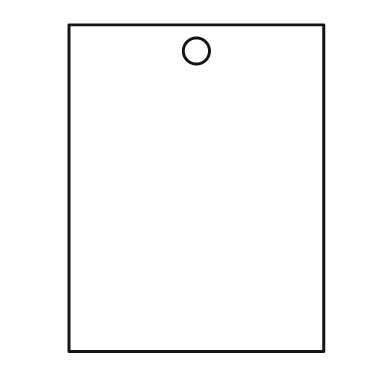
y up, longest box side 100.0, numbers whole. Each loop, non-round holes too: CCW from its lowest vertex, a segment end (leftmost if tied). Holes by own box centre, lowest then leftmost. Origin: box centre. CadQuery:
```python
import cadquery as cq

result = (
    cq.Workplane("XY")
    .moveTo(-39.0, -50.0)
    .lineTo(39.0, -50.0)
    .lineTo(39.0, 50.0)
    .lineTo(-39.0, 50.0)
    .close()
    .moveTo(0.0, 42.0)
    .circle(4.0)
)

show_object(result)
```